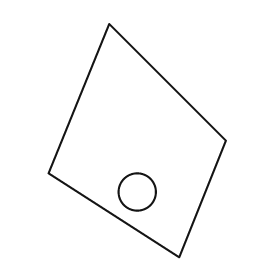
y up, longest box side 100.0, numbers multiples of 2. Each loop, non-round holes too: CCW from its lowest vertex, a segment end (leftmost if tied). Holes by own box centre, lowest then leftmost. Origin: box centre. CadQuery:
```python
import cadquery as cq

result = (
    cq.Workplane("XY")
    .moveTo(18.0, -50.0)
    .lineTo(38.0, 0.0)
    .lineTo(-12.0, 50.0)
    .lineTo(-38.0, -14.0)
    .close()
    .moveTo(0.0, -22.0)
    .circle(8.0)
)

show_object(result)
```